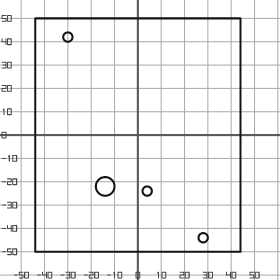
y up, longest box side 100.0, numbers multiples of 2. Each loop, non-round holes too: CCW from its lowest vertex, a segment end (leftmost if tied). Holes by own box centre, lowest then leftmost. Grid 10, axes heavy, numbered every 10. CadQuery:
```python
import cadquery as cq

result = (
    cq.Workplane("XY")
    .moveTo(-44.0, -50.0)
    .lineTo(44.0, -50.0)
    .lineTo(44.0, 50.0)
    .lineTo(-44.0, 50.0)
    .close()
    .moveTo(28.0, -44.0)
    .circle(2.0)
    .moveTo(4.0, -24.0)
    .circle(2.0)
    .moveTo(-14.0, -22.0)
    .circle(4.0)
    .moveTo(-30.0, 42.0)
    .circle(2.0)
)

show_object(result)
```